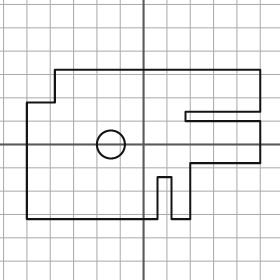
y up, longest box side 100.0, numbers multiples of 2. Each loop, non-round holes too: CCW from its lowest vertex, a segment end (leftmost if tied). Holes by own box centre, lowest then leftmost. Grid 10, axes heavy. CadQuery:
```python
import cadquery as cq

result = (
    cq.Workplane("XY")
    .moveTo(-50.0, -32.0)
    .lineTo(6.0, -32.0)
    .lineTo(6.0, -14.0)
    .lineTo(12.0, -14.0)
    .lineTo(12.0, -32.0)
    .lineTo(20.0, -32.0)
    .lineTo(20.0, -8.0)
    .lineTo(50.0, -8.0)
    .lineTo(50.0, 10.0)
    .lineTo(18.0, 10.0)
    .lineTo(18.0, 14.0)
    .lineTo(50.0, 14.0)
    .lineTo(50.0, 32.0)
    .lineTo(-38.0, 32.0)
    .lineTo(-38.0, 18.0)
    .lineTo(-50.0, 18.0)
    .close()
    .moveTo(-14.0, 0.0)
    .circle(6.0)
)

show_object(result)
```